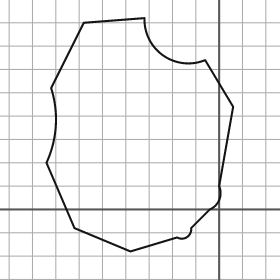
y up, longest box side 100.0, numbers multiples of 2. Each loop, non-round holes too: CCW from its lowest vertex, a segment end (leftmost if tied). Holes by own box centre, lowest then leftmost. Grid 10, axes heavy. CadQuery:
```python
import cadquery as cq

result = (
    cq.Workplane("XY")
    .moveTo(-38.0, -18.0)
    .lineTo(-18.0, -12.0)
    .threePointArc((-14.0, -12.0), (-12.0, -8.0))
    .lineTo(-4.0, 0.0)
    .threePointArc((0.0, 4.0), (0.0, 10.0))
    .lineTo(6.0, 44.0)
    .lineTo(-6.0, 64.0)
    .threePointArc((-24.0, 66.0), (-32.0, 82.0))
    .lineTo(-58.0, 80.0)
    .lineTo(-72.0, 52.0)
    .threePointArc((-70.0, 36.0), (-74.0, 20.0))
    .lineTo(-62.0, -8.0)
    .close()
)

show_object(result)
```